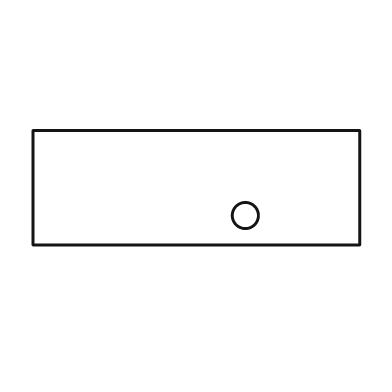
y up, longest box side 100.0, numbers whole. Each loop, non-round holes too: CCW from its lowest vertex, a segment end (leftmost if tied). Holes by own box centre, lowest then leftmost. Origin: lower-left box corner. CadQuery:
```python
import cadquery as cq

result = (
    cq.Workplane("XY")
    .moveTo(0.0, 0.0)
    .lineTo(100.0, 0.0)
    .lineTo(100.0, 35.0)
    .lineTo(0.0, 35.0)
    .close()
    .moveTo(65.0, 9.0)
    .circle(4.0)
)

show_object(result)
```